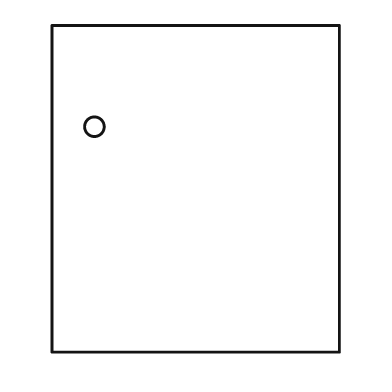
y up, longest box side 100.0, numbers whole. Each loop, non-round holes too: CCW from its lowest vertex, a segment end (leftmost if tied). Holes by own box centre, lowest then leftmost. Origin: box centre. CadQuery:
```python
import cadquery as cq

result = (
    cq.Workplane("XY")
    .moveTo(-44.0, -50.0)
    .lineTo(44.0, -50.0)
    .lineTo(44.0, 50.0)
    .lineTo(-44.0, 50.0)
    .close()
    .moveTo(-31.0, 19.0)
    .circle(3.0)
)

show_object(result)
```